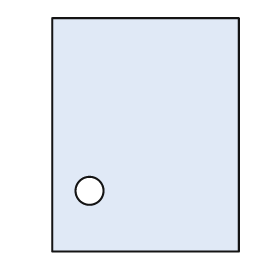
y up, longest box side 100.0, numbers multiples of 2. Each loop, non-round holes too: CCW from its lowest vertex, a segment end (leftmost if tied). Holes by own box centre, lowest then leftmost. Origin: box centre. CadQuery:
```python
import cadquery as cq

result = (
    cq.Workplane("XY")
    .moveTo(-40.0, -50.0)
    .lineTo(40.0, -50.0)
    .lineTo(40.0, 50.0)
    .lineTo(-40.0, 50.0)
    .close()
    .moveTo(-24.0, -24.0)
    .circle(6.0)
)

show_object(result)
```